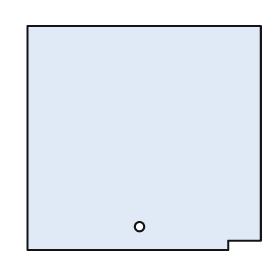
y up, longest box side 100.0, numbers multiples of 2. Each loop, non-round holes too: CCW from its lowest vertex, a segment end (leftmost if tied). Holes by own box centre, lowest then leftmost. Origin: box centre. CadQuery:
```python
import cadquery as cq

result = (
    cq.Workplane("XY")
    .moveTo(-50.0, -48.0)
    .lineTo(36.0, -48.0)
    .lineTo(36.0, -44.0)
    .lineTo(50.0, -44.0)
    .lineTo(50.0, 48.0)
    .lineTo(-50.0, 48.0)
    .close()
    .moveTo(-2.0, -38.0)
    .circle(2.0)
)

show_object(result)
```